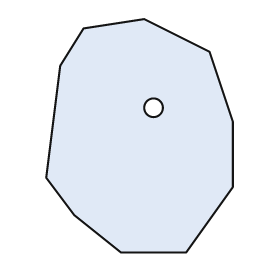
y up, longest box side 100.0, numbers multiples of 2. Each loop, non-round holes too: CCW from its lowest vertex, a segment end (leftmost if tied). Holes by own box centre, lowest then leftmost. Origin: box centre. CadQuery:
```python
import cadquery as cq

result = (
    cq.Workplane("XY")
    .moveTo(-8.0, -50.0)
    .lineTo(20.0, -50.0)
    .lineTo(40.0, -22.0)
    .lineTo(40.0, 6.0)
    .lineTo(30.0, 36.0)
    .lineTo(2.0, 50.0)
    .lineTo(-24.0, 46.0)
    .lineTo(-34.0, 30.0)
    .lineTo(-40.0, -18.0)
    .lineTo(-28.0, -34.0)
    .close()
    .moveTo(6.0, 12.0)
    .circle(4.0)
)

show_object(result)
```